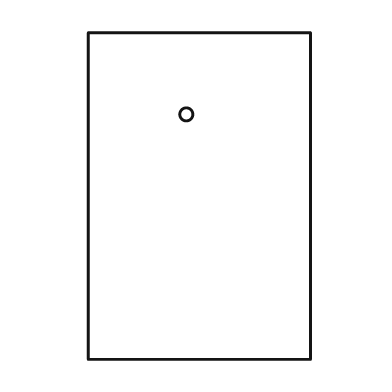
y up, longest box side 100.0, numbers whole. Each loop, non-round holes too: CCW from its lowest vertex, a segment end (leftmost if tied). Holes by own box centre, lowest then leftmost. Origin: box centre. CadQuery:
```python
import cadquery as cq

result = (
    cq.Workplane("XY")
    .moveTo(-34.0, -50.0)
    .lineTo(34.0, -50.0)
    .lineTo(34.0, 50.0)
    .lineTo(-34.0, 50.0)
    .close()
    .moveTo(-4.0, 25.0)
    .circle(2.0)
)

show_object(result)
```